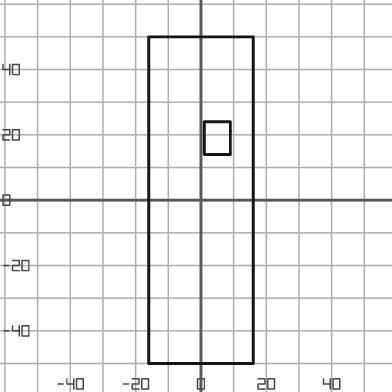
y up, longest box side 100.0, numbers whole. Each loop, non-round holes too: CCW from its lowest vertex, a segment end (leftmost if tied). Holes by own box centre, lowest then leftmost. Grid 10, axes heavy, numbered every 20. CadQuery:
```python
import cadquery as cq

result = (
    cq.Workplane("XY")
    .moveTo(-16.0, -50.0)
    .lineTo(16.0, -50.0)
    .lineTo(16.0, 50.0)
    .lineTo(-16.0, 50.0)
    .close()
    .moveTo(1.0, 14.0)
    .lineTo(9.0, 14.0)
    .lineTo(9.0, 24.0)
    .lineTo(1.0, 24.0)
    .close()
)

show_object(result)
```